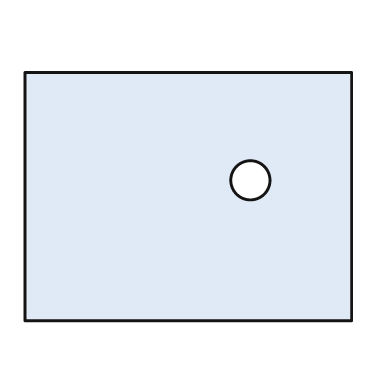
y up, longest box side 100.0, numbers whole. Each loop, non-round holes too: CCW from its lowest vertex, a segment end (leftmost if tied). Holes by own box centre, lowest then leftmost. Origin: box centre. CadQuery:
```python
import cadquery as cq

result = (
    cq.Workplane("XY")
    .moveTo(-50.0, -38.0)
    .lineTo(50.0, -38.0)
    .lineTo(50.0, 38.0)
    .lineTo(-50.0, 38.0)
    .close()
    .moveTo(19.0, 5.0)
    .circle(6.0)
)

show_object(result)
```